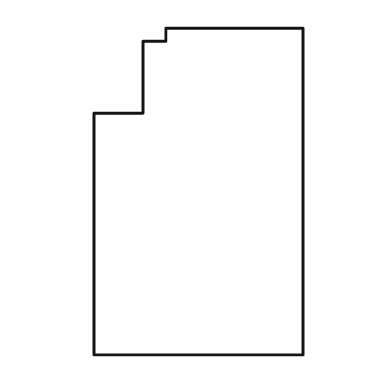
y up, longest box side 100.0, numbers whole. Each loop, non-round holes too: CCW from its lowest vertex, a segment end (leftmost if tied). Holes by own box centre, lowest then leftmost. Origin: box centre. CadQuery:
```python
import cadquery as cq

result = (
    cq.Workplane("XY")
    .moveTo(-32.0, -50.0)
    .lineTo(32.0, -50.0)
    .lineTo(32.0, 50.0)
    .lineTo(-10.0, 50.0)
    .lineTo(-10.0, 46.0)
    .lineTo(-17.0, 46.0)
    .lineTo(-17.0, 24.0)
    .lineTo(-32.0, 24.0)
    .close()
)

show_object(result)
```